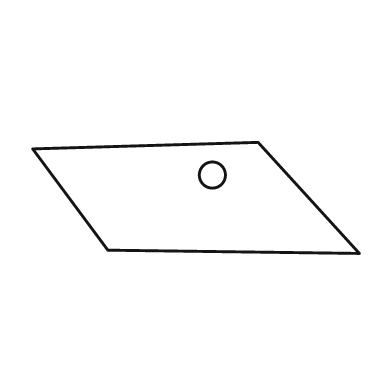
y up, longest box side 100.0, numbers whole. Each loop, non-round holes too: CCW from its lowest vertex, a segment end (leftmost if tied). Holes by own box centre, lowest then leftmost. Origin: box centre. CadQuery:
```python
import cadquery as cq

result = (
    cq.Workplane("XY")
    .moveTo(50.0, -17.0)
    .lineTo(19.0, 17.0)
    .lineTo(-50.0, 15.0)
    .lineTo(-27.0, -16.0)
    .close()
    .moveTo(5.0, 7.0)
    .circle(4.0)
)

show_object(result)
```